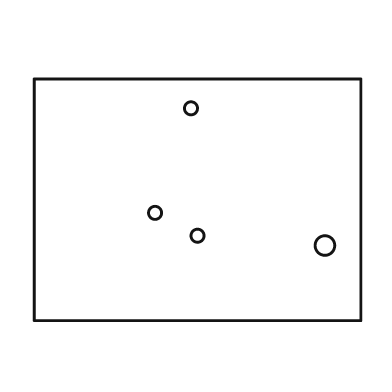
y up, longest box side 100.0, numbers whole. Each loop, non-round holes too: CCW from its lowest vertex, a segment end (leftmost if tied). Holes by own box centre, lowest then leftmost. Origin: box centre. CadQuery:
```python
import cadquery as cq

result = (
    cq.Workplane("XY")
    .moveTo(-50.0, -37.0)
    .lineTo(50.0, -37.0)
    .lineTo(50.0, 37.0)
    .lineTo(-50.0, 37.0)
    .close()
    .moveTo(39.0, -14.0)
    .circle(3.0)
    .moveTo(0.0, -11.0)
    .circle(2.0)
    .moveTo(-13.0, -4.0)
    .circle(2.0)
    .moveTo(-2.0, 28.0)
    .circle(2.0)
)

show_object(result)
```